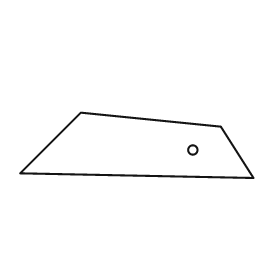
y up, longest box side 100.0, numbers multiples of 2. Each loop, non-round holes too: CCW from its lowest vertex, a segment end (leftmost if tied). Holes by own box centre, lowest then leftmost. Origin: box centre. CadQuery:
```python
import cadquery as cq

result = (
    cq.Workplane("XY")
    .moveTo(50.0, -14.0)
    .lineTo(36.0, 8.0)
    .lineTo(-24.0, 14.0)
    .lineTo(-50.0, -12.0)
    .close()
    .moveTo(24.0, -2.0)
    .circle(2.0)
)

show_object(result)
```